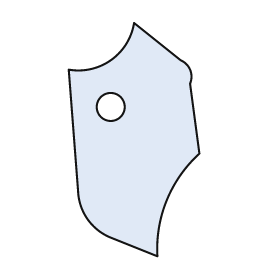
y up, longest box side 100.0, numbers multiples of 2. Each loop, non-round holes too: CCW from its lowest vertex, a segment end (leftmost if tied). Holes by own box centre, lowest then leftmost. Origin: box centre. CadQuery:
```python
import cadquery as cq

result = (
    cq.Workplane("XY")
    .moveTo(10.0, -50.0)
    .threePointArc((14.0, -26.0), (28.0, -6.0))
    .lineTo(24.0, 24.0)
    .threePointArc((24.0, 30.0), (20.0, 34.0))
    .lineTo(0.0, 50.0)
    .threePointArc((-10.0, 34.0), (-28.0, 30.0))
    .lineTo(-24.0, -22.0)
    .threePointArc((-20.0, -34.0), (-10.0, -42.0))
    .close()
    .moveTo(-10.0, 14.0)
    .circle(6.0)
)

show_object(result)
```